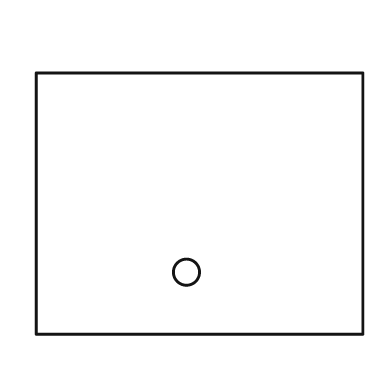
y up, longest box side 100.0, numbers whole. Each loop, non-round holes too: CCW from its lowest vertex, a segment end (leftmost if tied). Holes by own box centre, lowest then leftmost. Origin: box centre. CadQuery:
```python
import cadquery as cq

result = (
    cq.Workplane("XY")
    .moveTo(-50.0, -40.0)
    .lineTo(50.0, -40.0)
    .lineTo(50.0, 40.0)
    .lineTo(-50.0, 40.0)
    .close()
    .moveTo(-4.0, -21.0)
    .circle(4.0)
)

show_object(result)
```